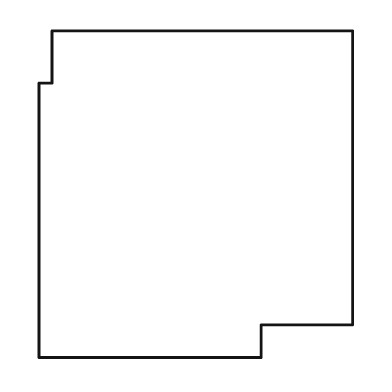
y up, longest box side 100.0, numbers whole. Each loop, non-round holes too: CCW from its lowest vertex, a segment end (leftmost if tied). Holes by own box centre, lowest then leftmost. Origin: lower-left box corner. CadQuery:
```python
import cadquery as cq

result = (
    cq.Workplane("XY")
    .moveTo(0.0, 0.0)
    .lineTo(68.0, 0.0)
    .lineTo(68.0, 10.0)
    .lineTo(96.0, 10.0)
    .lineTo(96.0, 100.0)
    .lineTo(4.0, 100.0)
    .lineTo(4.0, 84.0)
    .lineTo(0.0, 84.0)
    .close()
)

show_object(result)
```